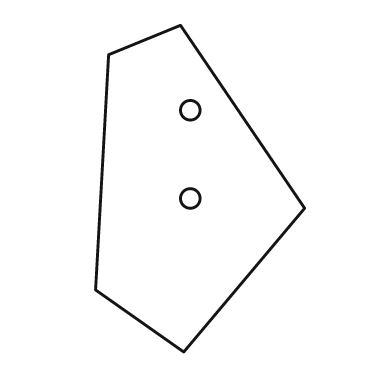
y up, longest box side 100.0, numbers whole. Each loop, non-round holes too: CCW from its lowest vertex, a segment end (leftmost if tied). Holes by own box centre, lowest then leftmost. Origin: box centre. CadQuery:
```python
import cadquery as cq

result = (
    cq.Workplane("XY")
    .moveTo(-5.0, -50.0)
    .lineTo(32.0, -6.0)
    .lineTo(-6.0, 50.0)
    .lineTo(-28.0, 41.0)
    .lineTo(-32.0, -31.0)
    .close()
    .moveTo(-3.0, -3.0)
    .circle(3.0)
    .moveTo(-3.0, 24.0)
    .circle(3.0)
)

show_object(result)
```